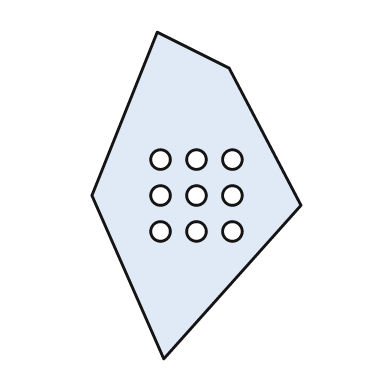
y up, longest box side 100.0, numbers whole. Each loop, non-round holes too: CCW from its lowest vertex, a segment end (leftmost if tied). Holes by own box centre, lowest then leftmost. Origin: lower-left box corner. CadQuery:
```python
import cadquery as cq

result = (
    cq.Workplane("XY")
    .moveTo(22.0, 0.0)
    .lineTo(64.0, 47.0)
    .lineTo(42.0, 89.0)
    .lineTo(20.0, 100.0)
    .lineTo(0.0, 50.0)
    .close()
    .moveTo(21.0, 39.0)
    .circle(3.0)
    .moveTo(32.0, 39.0)
    .circle(3.0)
    .moveTo(43.0, 39.0)
    .circle(3.0)
    .moveTo(21.0, 50.0)
    .circle(3.0)
    .moveTo(32.0, 50.0)
    .circle(3.0)
    .moveTo(43.0, 50.0)
    .circle(3.0)
    .moveTo(21.0, 61.0)
    .circle(3.0)
    .moveTo(32.0, 61.0)
    .circle(3.0)
    .moveTo(43.0, 61.0)
    .circle(3.0)
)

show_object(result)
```